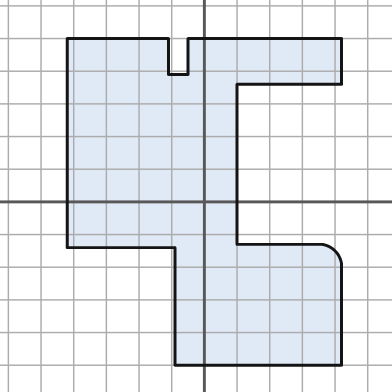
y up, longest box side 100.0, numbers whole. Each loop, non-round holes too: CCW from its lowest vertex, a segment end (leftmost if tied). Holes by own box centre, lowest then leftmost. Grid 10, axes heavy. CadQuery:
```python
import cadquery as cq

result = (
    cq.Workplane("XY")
    .moveTo(-9.0, -50.0)
    .lineTo(42.0, -50.0)
    .lineTo(42.0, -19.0)
    .threePointArc((40.0, -15.0), (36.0, -13.0))
    .lineTo(10.0, -13.0)
    .lineTo(10.0, 36.0)
    .lineTo(42.0, 36.0)
    .lineTo(42.0, 50.0)
    .lineTo(-5.0, 50.0)
    .lineTo(-5.0, 39.0)
    .lineTo(-11.0, 39.0)
    .lineTo(-11.0, 50.0)
    .lineTo(-42.0, 50.0)
    .lineTo(-42.0, -14.0)
    .lineTo(-9.0, -14.0)
    .close()
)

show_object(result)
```